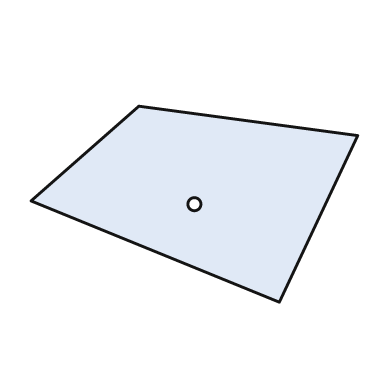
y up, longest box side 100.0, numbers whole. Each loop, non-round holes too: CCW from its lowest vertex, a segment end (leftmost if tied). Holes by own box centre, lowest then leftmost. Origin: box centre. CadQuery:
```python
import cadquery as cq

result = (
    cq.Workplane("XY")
    .moveTo(26.0, -30.0)
    .lineTo(50.0, 21.0)
    .lineTo(-17.0, 30.0)
    .lineTo(-50.0, 1.0)
    .close()
    .moveTo(0.0, 0.0)
    .circle(2.0)
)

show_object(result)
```